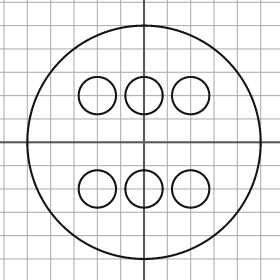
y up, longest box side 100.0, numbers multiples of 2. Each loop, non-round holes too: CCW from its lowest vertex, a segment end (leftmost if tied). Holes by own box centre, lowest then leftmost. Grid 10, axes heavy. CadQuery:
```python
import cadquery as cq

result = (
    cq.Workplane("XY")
    .moveTo(0.0, 0.0)
    .circle(50.0)
    .moveTo(-20.0, -20.0)
    .circle(8.0)
    .moveTo(0.0, -20.0)
    .circle(8.0)
    .moveTo(20.0, -20.0)
    .circle(8.0)
    .moveTo(-20.0, 20.0)
    .circle(8.0)
    .moveTo(0.0, 20.0)
    .circle(8.0)
    .moveTo(20.0, 20.0)
    .circle(8.0)
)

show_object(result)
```